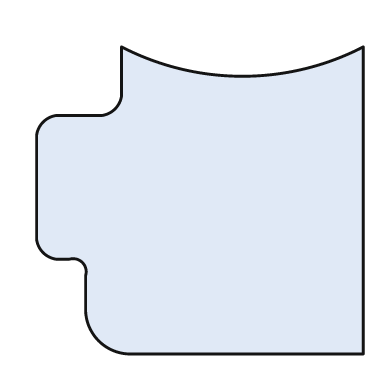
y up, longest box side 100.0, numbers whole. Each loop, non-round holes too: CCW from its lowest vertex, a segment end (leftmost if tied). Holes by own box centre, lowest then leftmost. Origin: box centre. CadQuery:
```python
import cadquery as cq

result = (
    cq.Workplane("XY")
    .moveTo(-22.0, -47.0)
    .lineTo(50.0, -47.0)
    .lineTo(50.0, 47.0)
    .threePointArc((13.0, 38.0), (-24.0, 47.0))
    .lineTo(-24.0, 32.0)
    .threePointArc((-26.0, 28.0), (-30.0, 26.0))
    .lineTo(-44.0, 26.0)
    .threePointArc((-48.0, 24.0), (-50.0, 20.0))
    .lineTo(-50.0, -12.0)
    .threePointArc((-48.0, -16.0), (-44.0, -18.0))
    .lineTo(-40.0, -18.0)
    .threePointArc((-36.0, -19.0), (-35.0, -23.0))
    .lineTo(-35.0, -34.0)
    .threePointArc((-31.0, -43.0), (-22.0, -47.0))
    .close()
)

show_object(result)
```